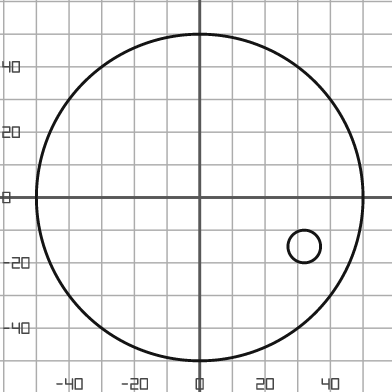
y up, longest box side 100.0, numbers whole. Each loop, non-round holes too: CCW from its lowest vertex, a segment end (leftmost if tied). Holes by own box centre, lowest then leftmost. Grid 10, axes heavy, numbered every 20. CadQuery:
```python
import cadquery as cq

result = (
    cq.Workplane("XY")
    .moveTo(0.0, 0.0)
    .circle(50.0)
    .moveTo(32.0, -15.0)
    .circle(5.0)
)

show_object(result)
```